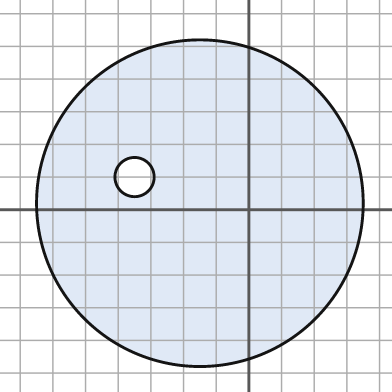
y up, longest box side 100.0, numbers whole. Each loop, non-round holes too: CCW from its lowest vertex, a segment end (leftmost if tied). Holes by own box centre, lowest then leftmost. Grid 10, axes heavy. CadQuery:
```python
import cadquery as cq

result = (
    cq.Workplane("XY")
    .moveTo(-15.0, 2.0)
    .circle(50.0)
    .moveTo(-35.0, 10.0)
    .circle(6.0)
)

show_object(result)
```